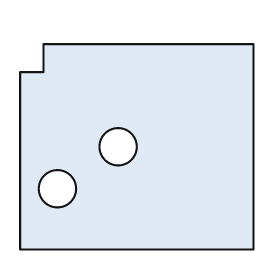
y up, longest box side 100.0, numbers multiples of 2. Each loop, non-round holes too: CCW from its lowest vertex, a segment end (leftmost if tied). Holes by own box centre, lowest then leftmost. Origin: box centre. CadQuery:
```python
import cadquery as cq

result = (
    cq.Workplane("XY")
    .moveTo(-50.0, -44.0)
    .lineTo(50.0, -44.0)
    .lineTo(50.0, 44.0)
    .lineTo(-40.0, 44.0)
    .lineTo(-40.0, 32.0)
    .lineTo(-50.0, 32.0)
    .close()
    .moveTo(-34.0, -18.0)
    .circle(8.0)
    .moveTo(-8.0, 0.0)
    .circle(8.0)
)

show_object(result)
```